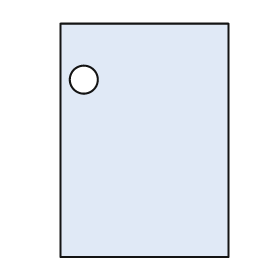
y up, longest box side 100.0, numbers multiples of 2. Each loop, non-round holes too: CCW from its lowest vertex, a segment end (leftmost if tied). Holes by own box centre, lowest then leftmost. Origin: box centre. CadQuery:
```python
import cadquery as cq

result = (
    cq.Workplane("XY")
    .moveTo(-36.0, -50.0)
    .lineTo(36.0, -50.0)
    .lineTo(36.0, 50.0)
    .lineTo(-36.0, 50.0)
    .close()
    .moveTo(-26.0, 26.0)
    .circle(6.0)
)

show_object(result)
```